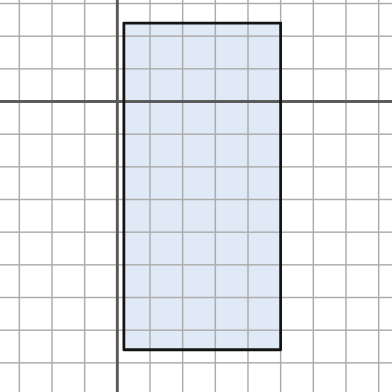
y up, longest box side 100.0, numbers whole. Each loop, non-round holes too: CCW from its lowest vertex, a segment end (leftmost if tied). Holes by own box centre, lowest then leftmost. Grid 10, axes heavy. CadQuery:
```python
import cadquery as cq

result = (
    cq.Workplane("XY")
    .moveTo(2.0, -76.0)
    .lineTo(50.0, -76.0)
    .lineTo(50.0, 24.0)
    .lineTo(2.0, 24.0)
    .close()
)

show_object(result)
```